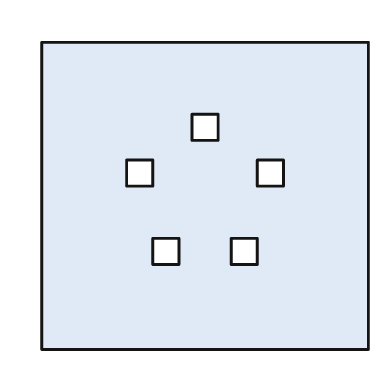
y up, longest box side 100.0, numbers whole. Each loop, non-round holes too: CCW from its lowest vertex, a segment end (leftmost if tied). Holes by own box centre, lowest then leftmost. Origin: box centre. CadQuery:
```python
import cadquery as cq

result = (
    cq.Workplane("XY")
    .moveTo(-50.0, -47.0)
    .lineTo(50.0, -47.0)
    .lineTo(50.0, 47.0)
    .lineTo(-50.0, 47.0)
    .close()
    .moveTo(-16.0, -21.0)
    .lineTo(-8.0, -21.0)
    .lineTo(-8.0, -13.0)
    .lineTo(-16.0, -13.0)
    .close()
    .moveTo(8.0, -21.0)
    .lineTo(16.0, -21.0)
    .lineTo(16.0, -13.0)
    .lineTo(8.0, -13.0)
    .close()
    .moveTo(-24.0, 3.0)
    .lineTo(-16.0, 3.0)
    .lineTo(-16.0, 11.0)
    .lineTo(-24.0, 11.0)
    .close()
    .moveTo(16.0, 3.0)
    .lineTo(24.0, 3.0)
    .lineTo(24.0, 11.0)
    .lineTo(16.0, 11.0)
    .close()
    .moveTo(-4.0, 17.0)
    .lineTo(4.0, 17.0)
    .lineTo(4.0, 25.0)
    .lineTo(-4.0, 25.0)
    .close()
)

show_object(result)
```